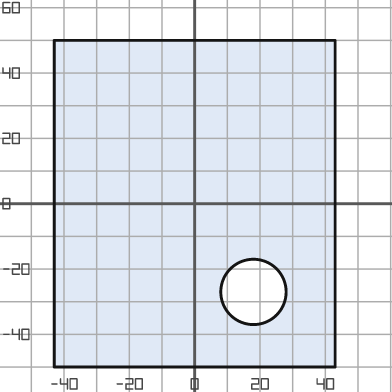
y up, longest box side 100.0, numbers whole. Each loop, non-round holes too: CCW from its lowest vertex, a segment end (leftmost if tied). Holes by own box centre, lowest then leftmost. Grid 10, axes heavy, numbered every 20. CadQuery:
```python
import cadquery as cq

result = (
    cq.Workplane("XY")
    .moveTo(-43.0, -50.0)
    .lineTo(43.0, -50.0)
    .lineTo(43.0, 50.0)
    .lineTo(-43.0, 50.0)
    .close()
    .moveTo(18.0, -27.0)
    .circle(10.0)
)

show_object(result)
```